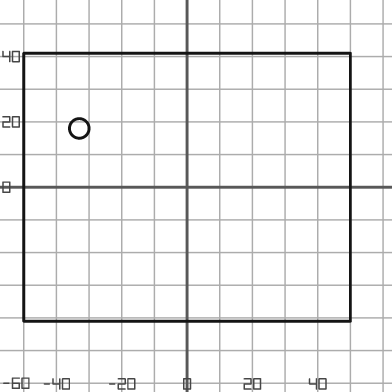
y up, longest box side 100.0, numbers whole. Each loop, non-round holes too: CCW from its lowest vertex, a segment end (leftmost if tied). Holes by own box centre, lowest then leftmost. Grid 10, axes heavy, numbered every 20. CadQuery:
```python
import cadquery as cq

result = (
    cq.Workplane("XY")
    .moveTo(-50.0, -41.0)
    .lineTo(50.0, -41.0)
    .lineTo(50.0, 41.0)
    .lineTo(-50.0, 41.0)
    .close()
    .moveTo(-33.0, 18.0)
    .circle(3.0)
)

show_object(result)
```